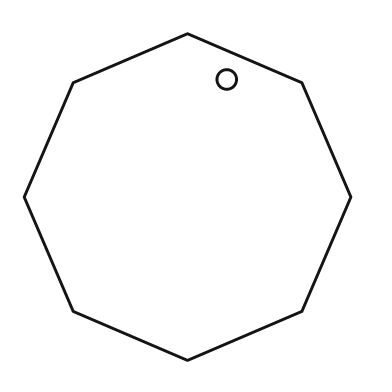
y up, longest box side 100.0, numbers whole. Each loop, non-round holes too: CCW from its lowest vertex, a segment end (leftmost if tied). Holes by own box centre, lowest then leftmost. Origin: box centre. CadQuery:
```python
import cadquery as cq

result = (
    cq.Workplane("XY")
    .moveTo(0.0, -50.0)
    .lineTo(35.0, -35.0)
    .lineTo(50.0, 0.0)
    .lineTo(35.0, 35.0)
    .lineTo(0.0, 50.0)
    .lineTo(-35.0, 35.0)
    .lineTo(-50.0, 0.0)
    .lineTo(-35.0, -35.0)
    .close()
    .moveTo(12.0, 36.0)
    .circle(3.0)
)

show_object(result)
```